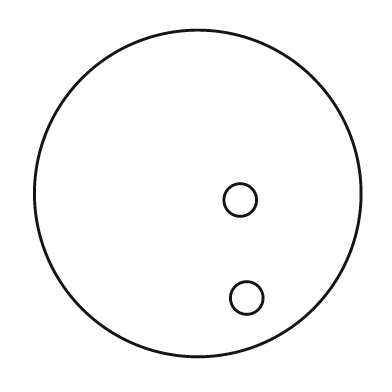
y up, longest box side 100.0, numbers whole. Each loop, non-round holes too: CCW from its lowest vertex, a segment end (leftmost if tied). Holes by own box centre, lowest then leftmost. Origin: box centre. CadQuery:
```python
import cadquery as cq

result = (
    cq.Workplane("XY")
    .moveTo(0.0, 0.0)
    .circle(50.0)
    .moveTo(15.0, -32.0)
    .circle(5.0)
    .moveTo(13.0, -2.0)
    .circle(5.0)
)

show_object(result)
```